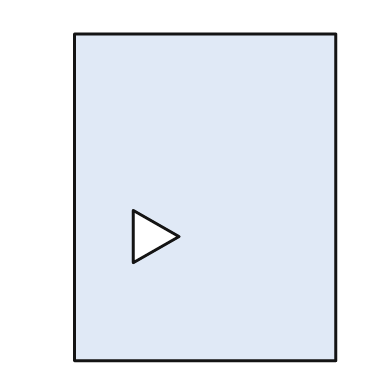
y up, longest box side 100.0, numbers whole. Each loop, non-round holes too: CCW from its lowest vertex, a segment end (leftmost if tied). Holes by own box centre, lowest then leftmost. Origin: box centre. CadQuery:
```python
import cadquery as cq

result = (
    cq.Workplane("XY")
    .moveTo(-40.0, -50.0)
    .lineTo(40.0, -50.0)
    .lineTo(40.0, 50.0)
    .lineTo(-40.0, 50.0)
    .close()
    .moveTo(-22.0, -20.0)
    .lineTo(-8.0, -12.0)
    .lineTo(-22.0, -4.0)
    .close()
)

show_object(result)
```